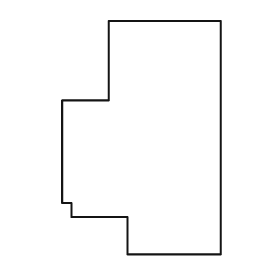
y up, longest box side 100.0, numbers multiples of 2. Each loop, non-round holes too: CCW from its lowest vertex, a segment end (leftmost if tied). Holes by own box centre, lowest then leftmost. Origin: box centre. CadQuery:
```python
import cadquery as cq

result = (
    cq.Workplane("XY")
    .moveTo(-6.0, -50.0)
    .lineTo(34.0, -50.0)
    .lineTo(34.0, 50.0)
    .lineTo(-14.0, 50.0)
    .lineTo(-14.0, 16.0)
    .lineTo(-34.0, 16.0)
    .lineTo(-34.0, -28.0)
    .lineTo(-30.0, -28.0)
    .lineTo(-30.0, -34.0)
    .lineTo(-6.0, -34.0)
    .close()
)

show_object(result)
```